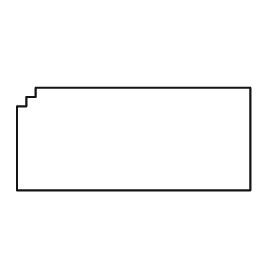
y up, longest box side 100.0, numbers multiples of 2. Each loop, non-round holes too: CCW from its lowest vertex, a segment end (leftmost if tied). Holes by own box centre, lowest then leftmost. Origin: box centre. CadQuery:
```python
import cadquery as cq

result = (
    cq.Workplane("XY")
    .moveTo(-50.0, -22.0)
    .lineTo(50.0, -22.0)
    .lineTo(50.0, 22.0)
    .lineTo(-42.0, 22.0)
    .lineTo(-42.0, 18.0)
    .lineTo(-46.0, 18.0)
    .lineTo(-46.0, 14.0)
    .lineTo(-50.0, 14.0)
    .close()
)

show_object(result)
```